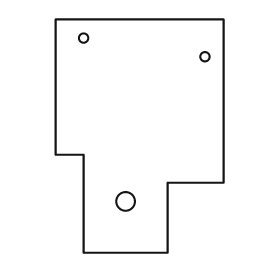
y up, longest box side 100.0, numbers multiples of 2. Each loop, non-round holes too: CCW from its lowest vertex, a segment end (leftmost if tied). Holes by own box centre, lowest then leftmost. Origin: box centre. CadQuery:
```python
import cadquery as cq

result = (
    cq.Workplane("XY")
    .moveTo(-24.0, -50.0)
    .lineTo(12.0, -50.0)
    .lineTo(12.0, -20.0)
    .lineTo(36.0, -20.0)
    .lineTo(36.0, 50.0)
    .lineTo(-36.0, 50.0)
    .lineTo(-36.0, -8.0)
    .lineTo(-24.0, -8.0)
    .close()
    .moveTo(-6.0, -28.0)
    .circle(4.0)
    .moveTo(28.0, 34.0)
    .circle(2.0)
    .moveTo(-24.0, 42.0)
    .circle(2.0)
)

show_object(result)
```